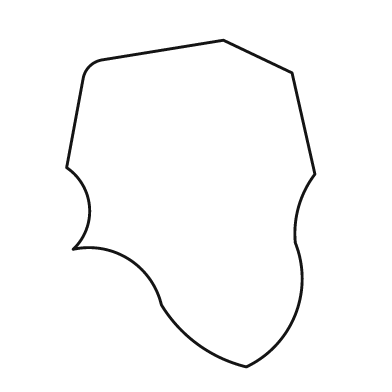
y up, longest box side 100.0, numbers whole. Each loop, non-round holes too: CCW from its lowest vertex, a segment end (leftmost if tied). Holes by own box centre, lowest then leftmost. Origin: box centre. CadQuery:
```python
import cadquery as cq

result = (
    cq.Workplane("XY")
    .moveTo(17.0, -50.0)
    .threePointArc((32.0, -34.0), (32.0, -12.0))
    .threePointArc((33.0, -1.0), (38.0, 9.0))
    .lineTo(31.0, 40.0)
    .lineTo(10.0, 50.0)
    .lineTo(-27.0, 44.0)
    .threePointArc((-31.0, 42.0), (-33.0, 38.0))
    .lineTo(-38.0, 11.0)
    .threePointArc((-31.0, -1.0), (-36.0, -14.0))
    .threePointArc((-19.0, -17.0), (-9.0, -31.0))
    .threePointArc((2.0, -43.0), (17.0, -50.0))
    .close()
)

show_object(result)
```